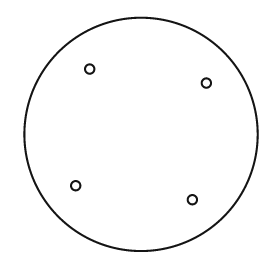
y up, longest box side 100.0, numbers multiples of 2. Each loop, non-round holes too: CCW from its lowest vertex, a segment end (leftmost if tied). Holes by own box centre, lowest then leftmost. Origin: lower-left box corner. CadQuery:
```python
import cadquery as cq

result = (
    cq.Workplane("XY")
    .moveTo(50.0, 50.0)
    .circle(50.0)
    .moveTo(72.0, 22.0)
    .circle(2.0)
    .moveTo(22.0, 28.0)
    .circle(2.0)
    .moveTo(78.0, 72.0)
    .circle(2.0)
    .moveTo(28.0, 78.0)
    .circle(2.0)
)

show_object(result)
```